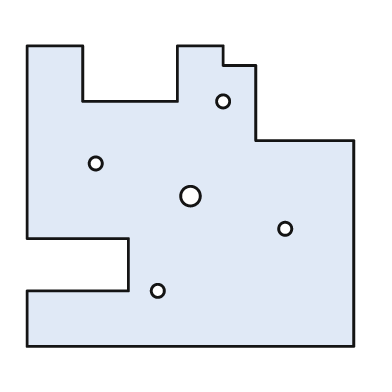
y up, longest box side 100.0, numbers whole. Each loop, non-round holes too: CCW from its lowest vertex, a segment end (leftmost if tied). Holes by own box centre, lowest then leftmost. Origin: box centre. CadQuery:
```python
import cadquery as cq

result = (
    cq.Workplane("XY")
    .moveTo(-50.0, -46.0)
    .lineTo(50.0, -46.0)
    .lineTo(50.0, 17.0)
    .lineTo(20.0, 17.0)
    .lineTo(20.0, 40.0)
    .lineTo(10.0, 40.0)
    .lineTo(10.0, 46.0)
    .lineTo(-4.0, 46.0)
    .lineTo(-4.0, 29.0)
    .lineTo(-33.0, 29.0)
    .lineTo(-33.0, 46.0)
    .lineTo(-50.0, 46.0)
    .lineTo(-50.0, -13.0)
    .lineTo(-19.0, -13.0)
    .lineTo(-19.0, -29.0)
    .lineTo(-50.0, -29.0)
    .close()
    .moveTo(-10.0, -29.0)
    .circle(2.0)
    .moveTo(29.0, -10.0)
    .circle(2.0)
    .moveTo(0.0, 0.0)
    .circle(3.0)
    .moveTo(-29.0, 10.0)
    .circle(2.0)
    .moveTo(10.0, 29.0)
    .circle(2.0)
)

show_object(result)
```